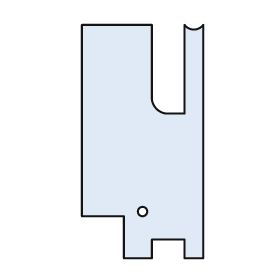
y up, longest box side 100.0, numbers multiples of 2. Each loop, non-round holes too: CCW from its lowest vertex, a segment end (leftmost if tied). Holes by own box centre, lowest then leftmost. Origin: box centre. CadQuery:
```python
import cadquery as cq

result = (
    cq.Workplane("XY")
    .moveTo(-8.0, -50.0)
    .lineTo(4.0, -50.0)
    .lineTo(4.0, -42.0)
    .lineTo(18.0, -42.0)
    .lineTo(18.0, -50.0)
    .lineTo(26.0, -50.0)
    .lineTo(26.0, 50.0)
    .threePointArc((22.0, 48.0), (18.0, 50.0))
    .lineTo(18.0, 12.0)
    .lineTo(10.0, 12.0)
    .threePointArc((6.0, 14.0), (4.0, 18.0))
    .lineTo(4.0, 50.0)
    .lineTo(-26.0, 50.0)
    .lineTo(-26.0, -32.0)
    .lineTo(-8.0, -32.0)
    .close()
    .moveTo(0.0, -30.0)
    .circle(2.0)
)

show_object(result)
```